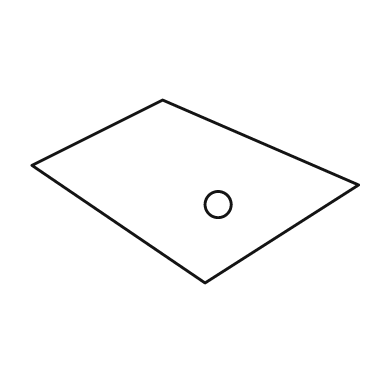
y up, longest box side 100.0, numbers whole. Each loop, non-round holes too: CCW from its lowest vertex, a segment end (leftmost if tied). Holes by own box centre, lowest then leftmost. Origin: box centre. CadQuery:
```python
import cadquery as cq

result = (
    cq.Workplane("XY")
    .moveTo(3.0, -28.0)
    .lineTo(50.0, 2.0)
    .lineTo(-10.0, 28.0)
    .lineTo(-50.0, 8.0)
    .close()
    .moveTo(7.0, -4.0)
    .circle(4.0)
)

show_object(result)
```